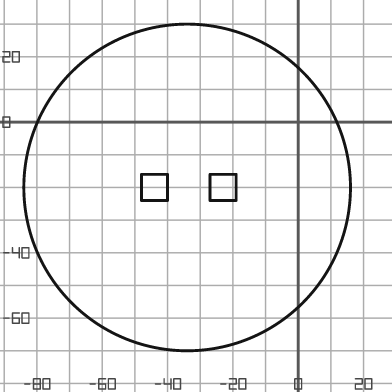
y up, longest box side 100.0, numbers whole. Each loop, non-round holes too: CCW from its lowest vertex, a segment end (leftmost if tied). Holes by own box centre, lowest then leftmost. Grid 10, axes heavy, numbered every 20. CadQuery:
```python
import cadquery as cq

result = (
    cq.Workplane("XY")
    .moveTo(-34.0, -20.0)
    .circle(50.0)
    .moveTo(-48.0, -24.0)
    .lineTo(-40.0, -24.0)
    .lineTo(-40.0, -16.0)
    .lineTo(-48.0, -16.0)
    .close()
    .moveTo(-27.0, -24.0)
    .lineTo(-19.0, -24.0)
    .lineTo(-19.0, -16.0)
    .lineTo(-27.0, -16.0)
    .close()
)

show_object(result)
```